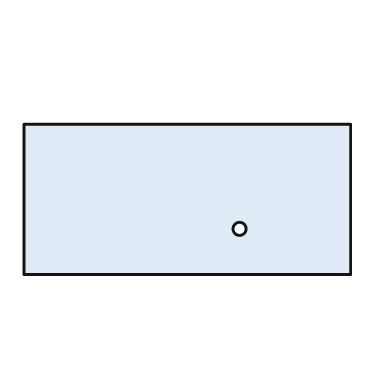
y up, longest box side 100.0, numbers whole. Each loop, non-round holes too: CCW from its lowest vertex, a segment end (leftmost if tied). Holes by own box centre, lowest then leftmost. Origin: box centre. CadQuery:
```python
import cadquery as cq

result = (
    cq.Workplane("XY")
    .moveTo(-50.0, -23.0)
    .lineTo(50.0, -23.0)
    .lineTo(50.0, 23.0)
    .lineTo(-50.0, 23.0)
    .close()
    .moveTo(16.0, -9.0)
    .circle(2.0)
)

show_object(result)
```